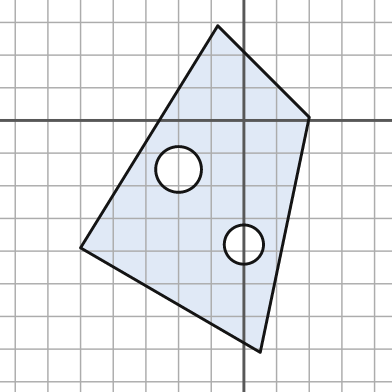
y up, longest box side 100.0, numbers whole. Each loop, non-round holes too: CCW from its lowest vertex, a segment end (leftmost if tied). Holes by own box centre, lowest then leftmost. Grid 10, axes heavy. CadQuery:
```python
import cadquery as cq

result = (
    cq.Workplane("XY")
    .moveTo(5.0, -71.0)
    .lineTo(20.0, 1.0)
    .lineTo(-8.0, 29.0)
    .lineTo(-50.0, -39.0)
    .close()
    .moveTo(0.0, -38.0)
    .circle(6.0)
    .moveTo(-20.0, -15.0)
    .circle(7.0)
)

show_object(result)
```